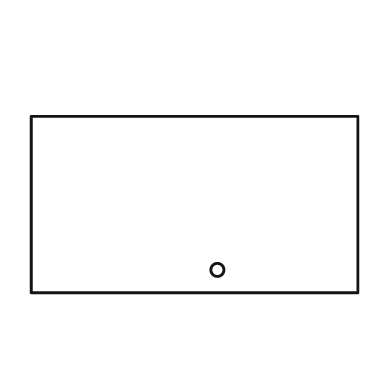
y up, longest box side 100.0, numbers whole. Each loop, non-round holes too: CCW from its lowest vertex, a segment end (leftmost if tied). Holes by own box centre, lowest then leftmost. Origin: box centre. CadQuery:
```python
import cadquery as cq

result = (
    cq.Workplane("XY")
    .moveTo(-50.0, -27.0)
    .lineTo(50.0, -27.0)
    .lineTo(50.0, 27.0)
    .lineTo(-50.0, 27.0)
    .close()
    .moveTo(7.0, -20.0)
    .circle(2.0)
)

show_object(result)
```